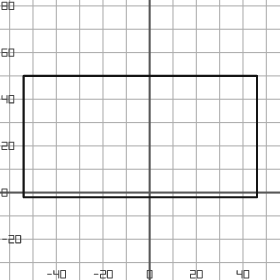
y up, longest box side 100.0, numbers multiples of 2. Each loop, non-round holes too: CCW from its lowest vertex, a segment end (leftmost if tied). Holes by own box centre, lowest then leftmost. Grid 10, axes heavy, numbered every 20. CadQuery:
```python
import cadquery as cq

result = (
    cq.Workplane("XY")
    .moveTo(-54.0, -2.0)
    .lineTo(46.0, -2.0)
    .lineTo(46.0, 50.0)
    .lineTo(-54.0, 50.0)
    .close()
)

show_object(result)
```